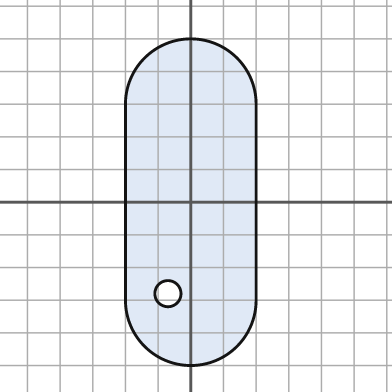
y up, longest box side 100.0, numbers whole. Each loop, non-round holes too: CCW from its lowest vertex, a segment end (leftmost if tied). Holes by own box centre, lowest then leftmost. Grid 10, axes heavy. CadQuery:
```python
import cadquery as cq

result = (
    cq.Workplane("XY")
    .moveTo(-20.0, -30.0)
    .threePointArc((0.0, -50.0), (20.0, -30.0))
    .lineTo(20.0, 30.0)
    .threePointArc((0.0, 50.0), (-20.0, 30.0))
    .close()
    .moveTo(-7.0, -28.0)
    .circle(4.0)
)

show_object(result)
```